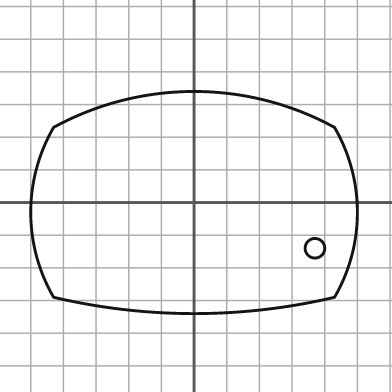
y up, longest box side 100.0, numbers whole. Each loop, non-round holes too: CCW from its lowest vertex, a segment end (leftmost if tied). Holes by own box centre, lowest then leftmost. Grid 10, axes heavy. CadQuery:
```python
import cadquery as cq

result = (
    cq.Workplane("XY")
    .moveTo(-43.0, -29.0)
    .threePointArc((0.0, -34.0), (43.0, -29.0))
    .threePointArc((50.0, -3.0), (43.0, 23.0))
    .threePointArc((0.0, 34.0), (-43.0, 23.0))
    .threePointArc((-50.0, -3.0), (-43.0, -29.0))
    .close()
    .moveTo(37.0, -14.0)
    .circle(3.0)
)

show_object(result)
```